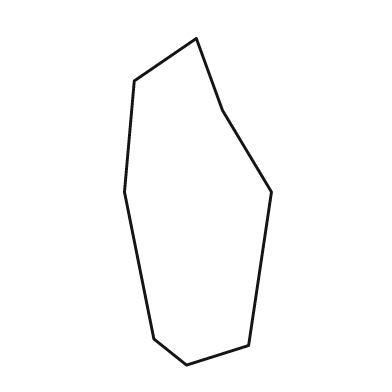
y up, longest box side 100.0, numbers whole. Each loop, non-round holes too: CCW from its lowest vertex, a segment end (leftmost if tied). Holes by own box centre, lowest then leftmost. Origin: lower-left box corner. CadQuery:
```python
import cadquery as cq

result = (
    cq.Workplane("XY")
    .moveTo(19.0, 0.0)
    .lineTo(38.0, 6.0)
    .lineTo(45.0, 53.0)
    .lineTo(30.0, 78.0)
    .lineTo(22.0, 100.0)
    .lineTo(3.0, 87.0)
    .lineTo(0.0, 53.0)
    .lineTo(9.0, 8.0)
    .close()
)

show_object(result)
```